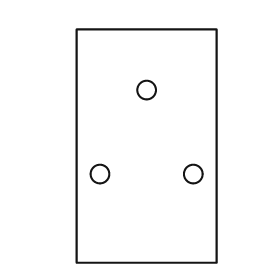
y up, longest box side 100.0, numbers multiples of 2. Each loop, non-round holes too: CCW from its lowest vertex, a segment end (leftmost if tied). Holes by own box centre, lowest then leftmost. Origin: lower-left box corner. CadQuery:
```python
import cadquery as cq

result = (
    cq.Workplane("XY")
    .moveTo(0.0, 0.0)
    .lineTo(60.0, 0.0)
    .lineTo(60.0, 100.0)
    .lineTo(0.0, 100.0)
    .close()
    .moveTo(10.0, 38.0)
    .circle(4.0)
    .moveTo(50.0, 38.0)
    .circle(4.0)
    .moveTo(30.0, 74.0)
    .circle(4.0)
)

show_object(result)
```